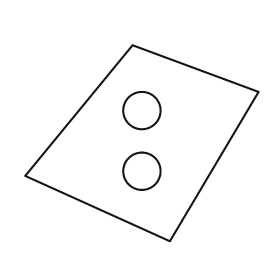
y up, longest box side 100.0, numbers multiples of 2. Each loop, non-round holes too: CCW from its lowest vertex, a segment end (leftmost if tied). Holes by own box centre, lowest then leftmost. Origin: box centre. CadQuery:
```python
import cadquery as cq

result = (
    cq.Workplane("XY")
    .moveTo(12.0, -42.0)
    .lineTo(50.0, 22.0)
    .lineTo(-4.0, 42.0)
    .lineTo(-50.0, -14.0)
    .close()
    .moveTo(0.0, -12.0)
    .circle(8.0)
    .moveTo(0.0, 14.0)
    .circle(8.0)
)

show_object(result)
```